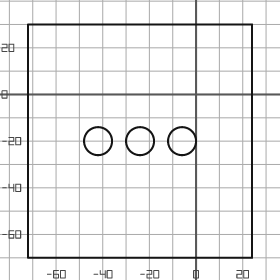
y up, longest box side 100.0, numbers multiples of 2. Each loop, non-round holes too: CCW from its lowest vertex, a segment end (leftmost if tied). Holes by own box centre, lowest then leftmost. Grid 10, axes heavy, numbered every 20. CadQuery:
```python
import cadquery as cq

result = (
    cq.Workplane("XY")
    .moveTo(-72.0, -70.0)
    .lineTo(24.0, -70.0)
    .lineTo(24.0, 30.0)
    .lineTo(-72.0, 30.0)
    .close()
    .moveTo(-42.0, -20.0)
    .circle(6.0)
    .moveTo(-24.0, -20.0)
    .circle(6.0)
    .moveTo(-6.0, -20.0)
    .circle(6.0)
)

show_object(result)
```